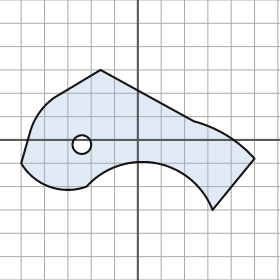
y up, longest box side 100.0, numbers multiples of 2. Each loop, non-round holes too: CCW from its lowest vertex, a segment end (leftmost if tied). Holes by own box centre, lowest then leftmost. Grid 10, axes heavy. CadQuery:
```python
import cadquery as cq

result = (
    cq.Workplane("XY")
    .moveTo(32.0, -30.0)
    .lineTo(50.0, -8.0)
    .threePointArc((38.0, 2.0), (24.0, 8.0))
    .lineTo(-16.0, 30.0)
    .lineTo(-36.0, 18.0)
    .threePointArc((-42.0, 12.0), (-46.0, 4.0))
    .lineTo(-50.0, -10.0)
    .threePointArc((-38.0, -20.0), (-22.0, -20.0))
    .threePointArc((8.0, -10.0), (32.0, -30.0))
    .close()
    .moveTo(-24.0, -2.0)
    .circle(4.0)
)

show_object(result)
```